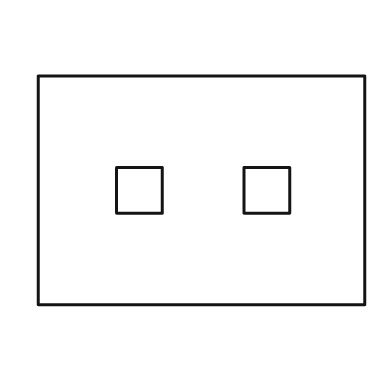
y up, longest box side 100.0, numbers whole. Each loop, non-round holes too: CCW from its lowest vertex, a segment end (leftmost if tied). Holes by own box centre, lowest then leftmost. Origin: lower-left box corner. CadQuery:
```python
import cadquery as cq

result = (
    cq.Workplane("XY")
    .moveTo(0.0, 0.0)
    .lineTo(100.0, 0.0)
    .lineTo(100.0, 70.0)
    .lineTo(0.0, 70.0)
    .close()
    .moveTo(24.0, 28.0)
    .lineTo(38.0, 28.0)
    .lineTo(38.0, 42.0)
    .lineTo(24.0, 42.0)
    .close()
    .moveTo(63.0, 28.0)
    .lineTo(77.0, 28.0)
    .lineTo(77.0, 42.0)
    .lineTo(63.0, 42.0)
    .close()
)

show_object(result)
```